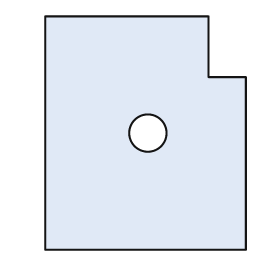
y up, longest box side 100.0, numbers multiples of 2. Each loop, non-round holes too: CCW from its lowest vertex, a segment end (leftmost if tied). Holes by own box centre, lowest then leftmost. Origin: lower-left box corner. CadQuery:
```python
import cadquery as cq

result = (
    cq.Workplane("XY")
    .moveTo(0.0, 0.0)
    .lineTo(86.0, 0.0)
    .lineTo(86.0, 74.0)
    .lineTo(70.0, 74.0)
    .lineTo(70.0, 100.0)
    .lineTo(0.0, 100.0)
    .close()
    .moveTo(44.0, 50.0)
    .circle(8.0)
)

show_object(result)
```